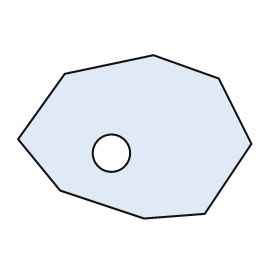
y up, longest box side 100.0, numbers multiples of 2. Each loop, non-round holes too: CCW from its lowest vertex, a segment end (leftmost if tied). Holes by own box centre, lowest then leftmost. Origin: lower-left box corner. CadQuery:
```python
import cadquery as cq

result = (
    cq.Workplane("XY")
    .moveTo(54.0, 0.0)
    .lineTo(80.0, 2.0)
    .lineTo(100.0, 32.0)
    .lineTo(86.0, 60.0)
    .lineTo(58.0, 70.0)
    .lineTo(20.0, 62.0)
    .lineTo(0.0, 34.0)
    .lineTo(18.0, 12.0)
    .close()
    .moveTo(40.0, 28.0)
    .circle(8.0)
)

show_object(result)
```